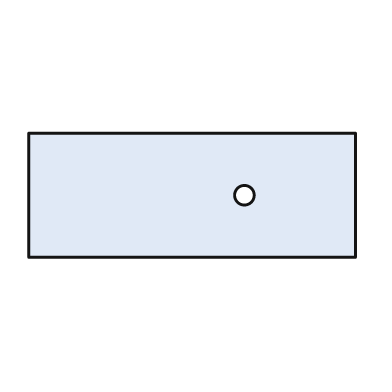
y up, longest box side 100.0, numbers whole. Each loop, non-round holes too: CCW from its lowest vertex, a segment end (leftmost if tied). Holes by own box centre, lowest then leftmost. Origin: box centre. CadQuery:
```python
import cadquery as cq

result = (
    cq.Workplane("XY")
    .moveTo(-50.0, -19.0)
    .lineTo(50.0, -19.0)
    .lineTo(50.0, 19.0)
    .lineTo(-50.0, 19.0)
    .close()
    .moveTo(16.0, 0.0)
    .circle(3.0)
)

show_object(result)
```